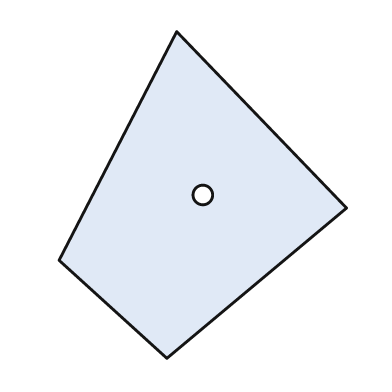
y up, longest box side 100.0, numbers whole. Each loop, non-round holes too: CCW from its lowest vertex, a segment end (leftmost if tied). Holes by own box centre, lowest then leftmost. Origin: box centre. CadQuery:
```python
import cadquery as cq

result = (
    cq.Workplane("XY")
    .moveTo(-11.0, -50.0)
    .lineTo(44.0, -4.0)
    .lineTo(-8.0, 50.0)
    .lineTo(-44.0, -20.0)
    .close()
    .moveTo(0.0, 0.0)
    .circle(3.0)
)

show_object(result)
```